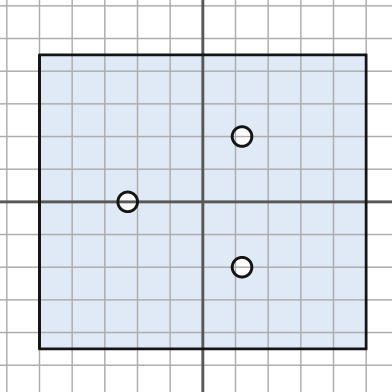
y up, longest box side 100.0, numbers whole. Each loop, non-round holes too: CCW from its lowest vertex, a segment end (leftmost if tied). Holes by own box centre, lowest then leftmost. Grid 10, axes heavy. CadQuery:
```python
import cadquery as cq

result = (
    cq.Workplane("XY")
    .moveTo(-50.0, -45.0)
    .lineTo(50.0, -45.0)
    .lineTo(50.0, 45.0)
    .lineTo(-50.0, 45.0)
    .close()
    .moveTo(12.0, -20.0)
    .circle(3.0)
    .moveTo(-23.0, 0.0)
    .circle(3.0)
    .moveTo(12.0, 20.0)
    .circle(3.0)
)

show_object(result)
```